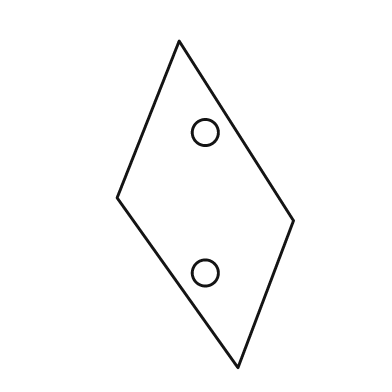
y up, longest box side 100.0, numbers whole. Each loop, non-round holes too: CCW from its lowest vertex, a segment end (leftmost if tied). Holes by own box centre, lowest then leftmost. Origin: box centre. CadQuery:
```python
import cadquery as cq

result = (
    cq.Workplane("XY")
    .moveTo(10.0, -50.0)
    .lineTo(27.0, -5.0)
    .lineTo(-8.0, 50.0)
    .lineTo(-27.0, 2.0)
    .close()
    .moveTo(0.0, -21.0)
    .circle(4.0)
    .moveTo(0.0, 22.0)
    .circle(4.0)
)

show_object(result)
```